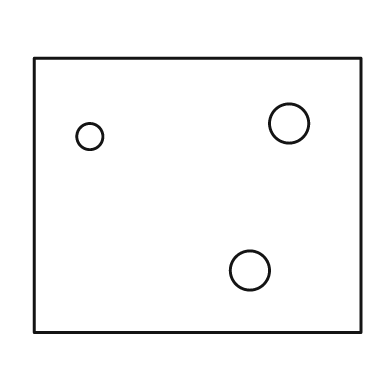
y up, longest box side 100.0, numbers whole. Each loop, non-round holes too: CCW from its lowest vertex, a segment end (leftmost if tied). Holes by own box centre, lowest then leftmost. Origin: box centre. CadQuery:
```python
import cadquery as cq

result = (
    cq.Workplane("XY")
    .moveTo(-50.0, -42.0)
    .lineTo(50.0, -42.0)
    .lineTo(50.0, 42.0)
    .lineTo(-50.0, 42.0)
    .close()
    .moveTo(16.0, -23.0)
    .circle(6.0)
    .moveTo(-33.0, 18.0)
    .circle(4.0)
    .moveTo(28.0, 22.0)
    .circle(6.0)
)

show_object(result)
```